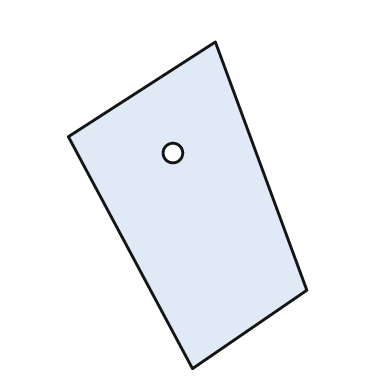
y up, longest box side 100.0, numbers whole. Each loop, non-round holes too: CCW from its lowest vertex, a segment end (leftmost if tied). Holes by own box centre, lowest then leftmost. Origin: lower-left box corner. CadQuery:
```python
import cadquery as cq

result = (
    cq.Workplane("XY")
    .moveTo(38.0, 0.0)
    .lineTo(73.0, 24.0)
    .lineTo(45.0, 100.0)
    .lineTo(0.0, 71.0)
    .close()
    .moveTo(32.0, 66.0)
    .circle(3.0)
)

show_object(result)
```